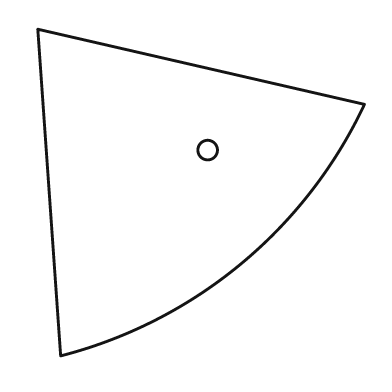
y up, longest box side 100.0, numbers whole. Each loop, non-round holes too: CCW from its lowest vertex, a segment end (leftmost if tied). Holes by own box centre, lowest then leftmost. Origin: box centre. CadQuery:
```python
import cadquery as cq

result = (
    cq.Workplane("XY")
    .moveTo(-43.0, -50.0)
    .threePointArc((12.0, -22.0), (50.0, 27.0))
    .lineTo(-50.0, 50.0)
    .close()
    .moveTo(2.0, 13.0)
    .circle(3.0)
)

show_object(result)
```